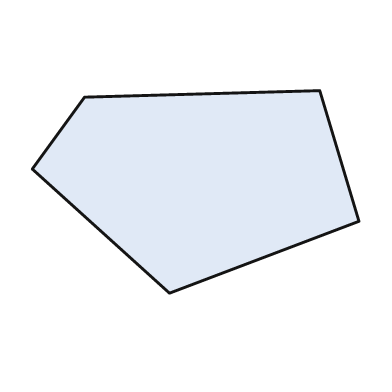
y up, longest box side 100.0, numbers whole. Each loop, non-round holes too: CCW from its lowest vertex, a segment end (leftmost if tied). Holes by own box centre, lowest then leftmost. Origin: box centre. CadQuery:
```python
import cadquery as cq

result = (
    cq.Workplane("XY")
    .moveTo(-8.0, -31.0)
    .lineTo(50.0, -9.0)
    .lineTo(38.0, 31.0)
    .lineTo(-34.0, 29.0)
    .lineTo(-50.0, 7.0)
    .close()
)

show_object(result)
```